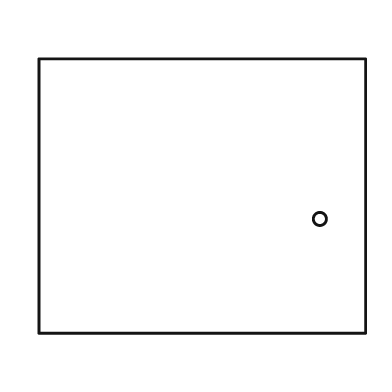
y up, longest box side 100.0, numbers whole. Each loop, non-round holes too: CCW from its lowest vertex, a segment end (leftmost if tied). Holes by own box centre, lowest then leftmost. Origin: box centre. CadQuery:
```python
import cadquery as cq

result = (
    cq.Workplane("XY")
    .moveTo(-50.0, -42.0)
    .lineTo(50.0, -42.0)
    .lineTo(50.0, 42.0)
    .lineTo(-50.0, 42.0)
    .close()
    .moveTo(36.0, -7.0)
    .circle(2.0)
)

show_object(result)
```